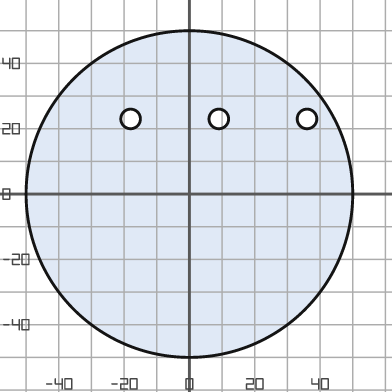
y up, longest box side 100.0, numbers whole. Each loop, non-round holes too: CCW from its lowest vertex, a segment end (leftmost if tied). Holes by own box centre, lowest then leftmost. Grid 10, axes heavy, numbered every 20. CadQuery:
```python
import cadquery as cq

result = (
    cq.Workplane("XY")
    .moveTo(0.0, 0.0)
    .circle(50.0)
    .moveTo(-18.0, 23.0)
    .circle(3.0)
    .moveTo(9.0, 23.0)
    .circle(3.0)
    .moveTo(36.0, 23.0)
    .circle(3.0)
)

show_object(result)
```